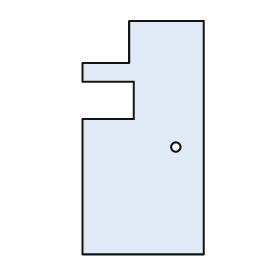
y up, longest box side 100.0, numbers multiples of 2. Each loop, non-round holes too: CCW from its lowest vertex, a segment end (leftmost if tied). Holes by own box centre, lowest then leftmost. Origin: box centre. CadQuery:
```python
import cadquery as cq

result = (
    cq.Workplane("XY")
    .moveTo(-26.0, -50.0)
    .lineTo(26.0, -50.0)
    .lineTo(26.0, 50.0)
    .lineTo(-6.0, 50.0)
    .lineTo(-6.0, 32.0)
    .lineTo(-26.0, 32.0)
    .lineTo(-26.0, 24.0)
    .lineTo(-4.0, 24.0)
    .lineTo(-4.0, 8.0)
    .lineTo(-26.0, 8.0)
    .close()
    .moveTo(14.0, -4.0)
    .circle(2.0)
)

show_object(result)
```